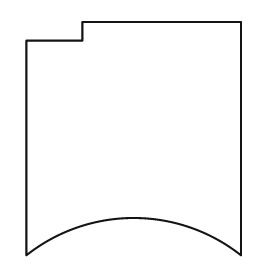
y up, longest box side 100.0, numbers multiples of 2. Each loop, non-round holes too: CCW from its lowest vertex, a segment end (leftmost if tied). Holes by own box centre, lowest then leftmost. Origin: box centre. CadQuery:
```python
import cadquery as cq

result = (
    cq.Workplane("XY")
    .moveTo(-46.0, -50.0)
    .threePointArc((0.0, -34.0), (46.0, -50.0))
    .lineTo(46.0, 50.0)
    .lineTo(-22.0, 50.0)
    .lineTo(-22.0, 42.0)
    .lineTo(-46.0, 42.0)
    .close()
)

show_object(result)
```